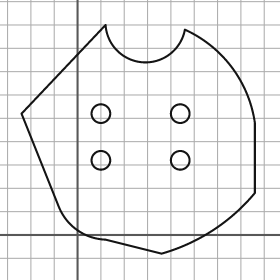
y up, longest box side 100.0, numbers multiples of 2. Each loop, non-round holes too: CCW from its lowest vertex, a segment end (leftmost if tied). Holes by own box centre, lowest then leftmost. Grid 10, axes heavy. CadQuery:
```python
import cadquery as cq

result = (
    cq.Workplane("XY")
    .moveTo(36.0, -8.0)
    .threePointArc((58.0, 2.0), (76.0, 18.0))
    .lineTo(76.0, 48.0)
    .threePointArc((66.0, 72.0), (46.0, 88.0))
    .threePointArc((28.0, 74.0), (12.0, 90.0))
    .lineTo(-24.0, 52.0)
    .lineTo(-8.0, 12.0)
    .threePointArc((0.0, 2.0), (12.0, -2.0))
    .close()
    .moveTo(10.0, 32.0)
    .circle(4.0)
    .moveTo(44.0, 32.0)
    .circle(4.0)
    .moveTo(10.0, 52.0)
    .circle(4.0)
    .moveTo(44.0, 52.0)
    .circle(4.0)
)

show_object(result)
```